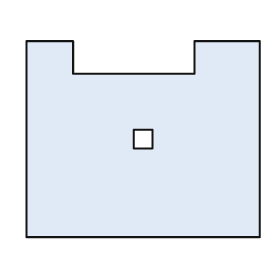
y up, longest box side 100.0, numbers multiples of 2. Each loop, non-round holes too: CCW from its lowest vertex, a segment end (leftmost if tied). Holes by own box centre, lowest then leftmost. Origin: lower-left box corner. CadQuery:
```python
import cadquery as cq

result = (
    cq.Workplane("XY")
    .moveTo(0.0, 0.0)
    .lineTo(100.0, 0.0)
    .lineTo(100.0, 84.0)
    .lineTo(72.0, 84.0)
    .lineTo(72.0, 70.0)
    .lineTo(20.0, 70.0)
    .lineTo(20.0, 84.0)
    .lineTo(0.0, 84.0)
    .close()
    .moveTo(46.0, 38.0)
    .lineTo(54.0, 38.0)
    .lineTo(54.0, 46.0)
    .lineTo(46.0, 46.0)
    .close()
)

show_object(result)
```